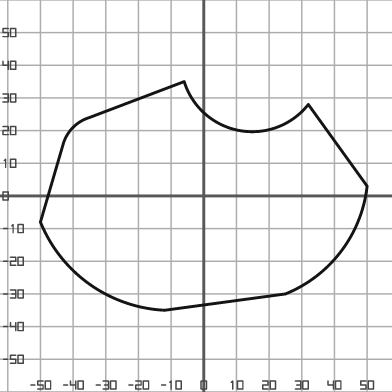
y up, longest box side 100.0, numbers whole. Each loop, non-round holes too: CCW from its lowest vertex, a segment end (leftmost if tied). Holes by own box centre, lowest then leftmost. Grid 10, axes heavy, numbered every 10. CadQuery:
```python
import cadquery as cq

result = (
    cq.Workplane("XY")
    .moveTo(-12.0, -35.0)
    .lineTo(25.0, -30.0)
    .threePointArc((42.0, -17.0), (50.0, 3.0))
    .lineTo(32.0, 28.0)
    .threePointArc((11.0, 20.0), (-6.0, 35.0))
    .lineTo(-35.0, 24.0)
    .threePointArc((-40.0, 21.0), (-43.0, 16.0))
    .lineTo(-50.0, -8.0)
    .threePointArc((-35.0, -27.0), (-12.0, -35.0))
    .close()
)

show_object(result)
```